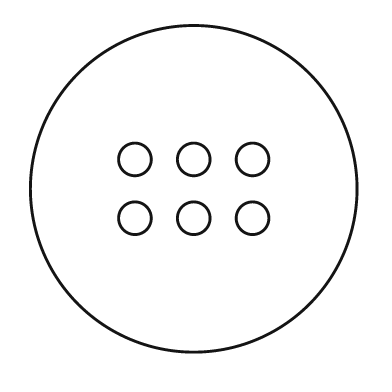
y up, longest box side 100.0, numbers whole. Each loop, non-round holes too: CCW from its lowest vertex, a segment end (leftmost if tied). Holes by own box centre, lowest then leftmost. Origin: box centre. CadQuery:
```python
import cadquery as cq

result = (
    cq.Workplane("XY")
    .moveTo(0.0, 0.0)
    .circle(50.0)
    .moveTo(-18.0, -9.0)
    .circle(5.0)
    .moveTo(0.0, -9.0)
    .circle(5.0)
    .moveTo(18.0, -9.0)
    .circle(5.0)
    .moveTo(-18.0, 9.0)
    .circle(5.0)
    .moveTo(0.0, 9.0)
    .circle(5.0)
    .moveTo(18.0, 9.0)
    .circle(5.0)
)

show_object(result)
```